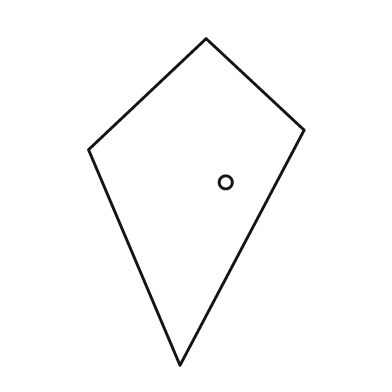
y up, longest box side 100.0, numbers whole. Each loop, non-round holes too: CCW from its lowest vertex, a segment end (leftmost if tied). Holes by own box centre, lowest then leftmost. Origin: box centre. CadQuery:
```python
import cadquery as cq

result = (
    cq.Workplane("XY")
    .moveTo(-5.0, -50.0)
    .lineTo(33.0, 22.0)
    .lineTo(3.0, 50.0)
    .lineTo(-33.0, 16.0)
    .close()
    .moveTo(9.0, 6.0)
    .circle(2.0)
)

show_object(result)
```